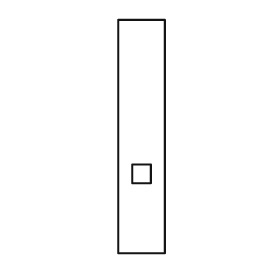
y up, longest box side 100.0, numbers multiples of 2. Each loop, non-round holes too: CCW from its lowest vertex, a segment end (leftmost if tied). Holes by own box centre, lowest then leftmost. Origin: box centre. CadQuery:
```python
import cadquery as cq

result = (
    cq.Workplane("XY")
    .moveTo(-10.0, -50.0)
    .lineTo(10.0, -50.0)
    .lineTo(10.0, 50.0)
    .lineTo(-10.0, 50.0)
    .close()
    .moveTo(-4.0, -20.0)
    .lineTo(4.0, -20.0)
    .lineTo(4.0, -12.0)
    .lineTo(-4.0, -12.0)
    .close()
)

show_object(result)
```